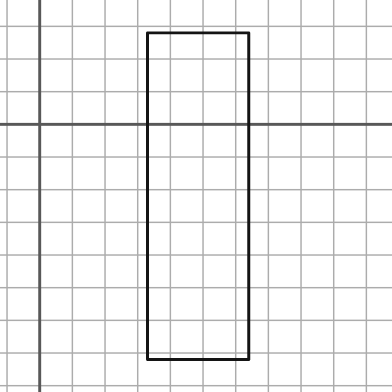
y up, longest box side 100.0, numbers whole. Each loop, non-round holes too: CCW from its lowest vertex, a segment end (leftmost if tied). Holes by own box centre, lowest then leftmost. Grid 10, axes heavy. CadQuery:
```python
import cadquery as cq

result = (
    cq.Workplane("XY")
    .moveTo(33.0, -72.0)
    .lineTo(64.0, -72.0)
    .lineTo(64.0, 28.0)
    .lineTo(33.0, 28.0)
    .close()
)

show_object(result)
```